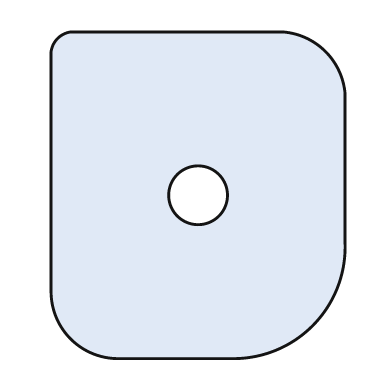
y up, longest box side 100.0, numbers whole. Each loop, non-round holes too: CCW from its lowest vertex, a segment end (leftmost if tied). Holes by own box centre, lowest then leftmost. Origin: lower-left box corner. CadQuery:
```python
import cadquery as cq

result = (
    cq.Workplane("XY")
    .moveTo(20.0, 0.0)
    .lineTo(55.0, 0.0)
    .threePointArc((80.0, 10.0), (90.0, 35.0))
    .lineTo(90.0, 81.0)
    .threePointArc((84.0, 94.0), (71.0, 100.0))
    .lineTo(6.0, 100.0)
    .threePointArc((2.0, 98.0), (0.0, 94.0))
    .lineTo(0.0, 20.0)
    .threePointArc((6.0, 6.0), (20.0, 0.0))
    .close()
    .moveTo(45.0, 50.0)
    .circle(9.0)
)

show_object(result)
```